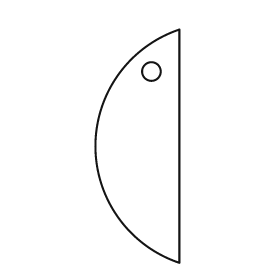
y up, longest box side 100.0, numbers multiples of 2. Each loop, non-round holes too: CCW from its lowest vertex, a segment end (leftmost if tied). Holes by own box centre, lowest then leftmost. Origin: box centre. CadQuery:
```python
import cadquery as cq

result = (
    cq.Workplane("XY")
    .moveTo(18.0, -50.0)
    .lineTo(18.0, 50.0)
    .threePointArc((-18.0, 0.0), (18.0, -50.0))
    .close()
    .moveTo(6.0, 32.0)
    .circle(4.0)
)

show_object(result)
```